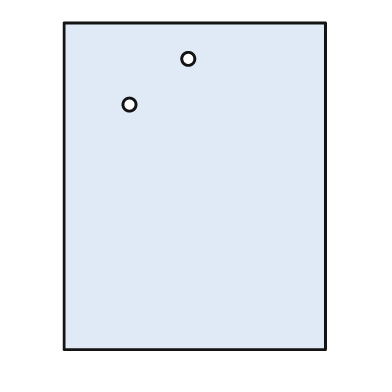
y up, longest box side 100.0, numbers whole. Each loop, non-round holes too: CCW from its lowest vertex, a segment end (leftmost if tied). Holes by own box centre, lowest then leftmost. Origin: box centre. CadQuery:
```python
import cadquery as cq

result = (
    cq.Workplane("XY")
    .moveTo(-40.0, -50.0)
    .lineTo(40.0, -50.0)
    .lineTo(40.0, 50.0)
    .lineTo(-40.0, 50.0)
    .close()
    .moveTo(-20.0, 25.0)
    .circle(2.0)
    .moveTo(-2.0, 39.0)
    .circle(2.0)
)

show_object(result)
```